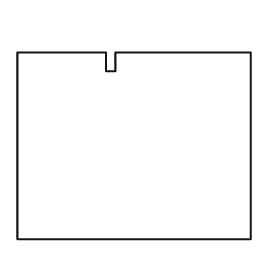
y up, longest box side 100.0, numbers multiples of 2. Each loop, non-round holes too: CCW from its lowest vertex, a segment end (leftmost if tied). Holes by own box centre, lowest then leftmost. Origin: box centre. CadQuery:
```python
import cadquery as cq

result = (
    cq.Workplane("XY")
    .moveTo(-50.0, -40.0)
    .lineTo(50.0, -40.0)
    .lineTo(50.0, 40.0)
    .lineTo(-8.0, 40.0)
    .lineTo(-8.0, 32.0)
    .lineTo(-12.0, 32.0)
    .lineTo(-12.0, 40.0)
    .lineTo(-50.0, 40.0)
    .close()
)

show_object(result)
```